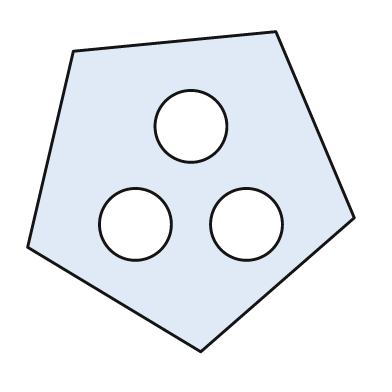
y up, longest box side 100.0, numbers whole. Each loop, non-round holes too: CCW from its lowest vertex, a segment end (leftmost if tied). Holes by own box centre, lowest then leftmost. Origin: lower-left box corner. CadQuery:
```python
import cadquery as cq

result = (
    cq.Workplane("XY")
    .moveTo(53.0, 0.0)
    .lineTo(100.0, 41.0)
    .lineTo(76.0, 98.0)
    .lineTo(14.0, 92.0)
    .lineTo(0.0, 32.0)
    .close()
    .moveTo(33.0, 39.0)
    .circle(11.0)
    .moveTo(67.0, 39.0)
    .circle(11.0)
    .moveTo(50.0, 69.0)
    .circle(11.0)
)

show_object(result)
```